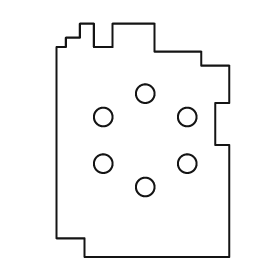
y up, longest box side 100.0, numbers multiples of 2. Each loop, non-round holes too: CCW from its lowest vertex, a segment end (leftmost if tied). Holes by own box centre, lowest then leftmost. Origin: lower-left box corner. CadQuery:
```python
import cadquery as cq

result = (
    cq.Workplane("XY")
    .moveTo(12.0, 0.0)
    .lineTo(74.0, 0.0)
    .lineTo(74.0, 48.0)
    .lineTo(68.0, 48.0)
    .lineTo(68.0, 66.0)
    .lineTo(74.0, 66.0)
    .lineTo(74.0, 82.0)
    .lineTo(62.0, 82.0)
    .lineTo(62.0, 88.0)
    .lineTo(42.0, 88.0)
    .lineTo(42.0, 100.0)
    .lineTo(24.0, 100.0)
    .lineTo(24.0, 90.0)
    .lineTo(16.0, 90.0)
    .lineTo(16.0, 100.0)
    .lineTo(10.0, 100.0)
    .lineTo(10.0, 94.0)
    .lineTo(4.0, 94.0)
    .lineTo(4.0, 90.0)
    .lineTo(0.0, 90.0)
    .lineTo(0.0, 8.0)
    .lineTo(12.0, 8.0)
    .close()
    .moveTo(38.0, 30.0)
    .circle(4.0)
    .moveTo(20.0, 40.0)
    .circle(4.0)
    .moveTo(56.0, 40.0)
    .circle(4.0)
    .moveTo(20.0, 60.0)
    .circle(4.0)
    .moveTo(56.0, 60.0)
    .circle(4.0)
    .moveTo(38.0, 70.0)
    .circle(4.0)
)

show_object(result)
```